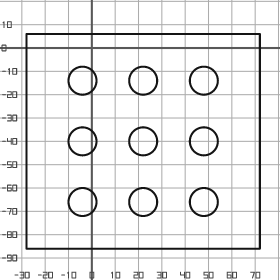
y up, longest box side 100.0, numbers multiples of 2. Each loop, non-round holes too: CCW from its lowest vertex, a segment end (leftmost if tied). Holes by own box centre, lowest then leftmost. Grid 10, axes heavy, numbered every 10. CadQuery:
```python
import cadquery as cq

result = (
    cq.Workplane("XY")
    .moveTo(-28.0, -86.0)
    .lineTo(72.0, -86.0)
    .lineTo(72.0, 6.0)
    .lineTo(-28.0, 6.0)
    .close()
    .moveTo(-4.0, -66.0)
    .circle(6.0)
    .moveTo(22.0, -66.0)
    .circle(6.0)
    .moveTo(48.0, -66.0)
    .circle(6.0)
    .moveTo(-4.0, -40.0)
    .circle(6.0)
    .moveTo(22.0, -40.0)
    .circle(6.0)
    .moveTo(48.0, -40.0)
    .circle(6.0)
    .moveTo(-4.0, -14.0)
    .circle(6.0)
    .moveTo(22.0, -14.0)
    .circle(6.0)
    .moveTo(48.0, -14.0)
    .circle(6.0)
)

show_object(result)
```